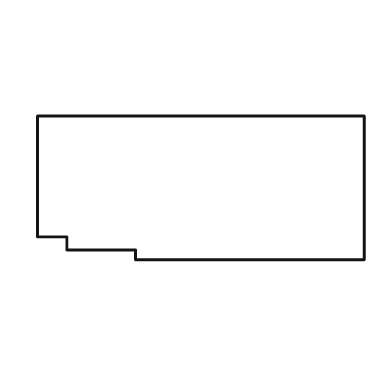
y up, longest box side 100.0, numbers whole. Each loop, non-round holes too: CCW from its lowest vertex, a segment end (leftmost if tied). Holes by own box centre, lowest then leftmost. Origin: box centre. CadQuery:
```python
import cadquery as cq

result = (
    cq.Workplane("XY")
    .moveTo(-20.0, -22.0)
    .lineTo(50.0, -22.0)
    .lineTo(50.0, 22.0)
    .lineTo(-50.0, 22.0)
    .lineTo(-50.0, -15.0)
    .lineTo(-41.0, -15.0)
    .lineTo(-41.0, -19.0)
    .lineTo(-20.0, -19.0)
    .close()
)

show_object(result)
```